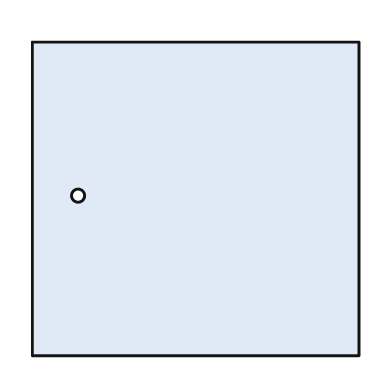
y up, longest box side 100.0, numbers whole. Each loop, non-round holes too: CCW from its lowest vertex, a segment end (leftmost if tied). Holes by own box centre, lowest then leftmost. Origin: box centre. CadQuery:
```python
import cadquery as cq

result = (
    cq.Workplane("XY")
    .moveTo(-50.0, -48.0)
    .lineTo(50.0, -48.0)
    .lineTo(50.0, 48.0)
    .lineTo(-50.0, 48.0)
    .close()
    .moveTo(-36.0, 1.0)
    .circle(2.0)
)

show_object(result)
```